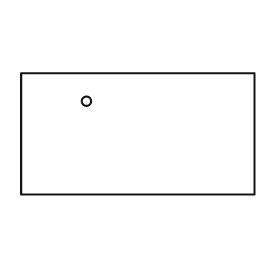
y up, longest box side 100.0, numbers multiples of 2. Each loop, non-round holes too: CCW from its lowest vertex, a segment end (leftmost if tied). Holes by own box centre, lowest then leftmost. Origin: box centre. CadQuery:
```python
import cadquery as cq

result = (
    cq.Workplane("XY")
    .moveTo(-50.0, -26.0)
    .lineTo(50.0, -26.0)
    .lineTo(50.0, 26.0)
    .lineTo(-50.0, 26.0)
    .close()
    .moveTo(-22.0, 14.0)
    .circle(2.0)
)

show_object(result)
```